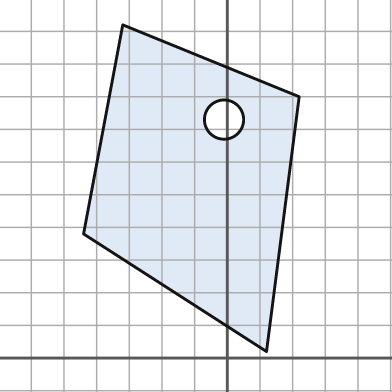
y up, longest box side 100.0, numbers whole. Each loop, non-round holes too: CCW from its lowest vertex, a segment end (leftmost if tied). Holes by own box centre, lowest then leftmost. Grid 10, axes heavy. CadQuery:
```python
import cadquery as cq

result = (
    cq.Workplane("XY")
    .moveTo(12.0, 2.0)
    .lineTo(22.0, 80.0)
    .lineTo(-32.0, 102.0)
    .lineTo(-44.0, 38.0)
    .close()
    .moveTo(-1.0, 73.0)
    .circle(6.0)
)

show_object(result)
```